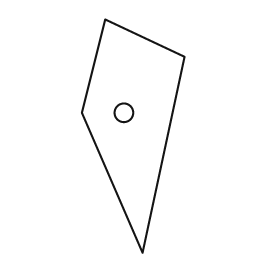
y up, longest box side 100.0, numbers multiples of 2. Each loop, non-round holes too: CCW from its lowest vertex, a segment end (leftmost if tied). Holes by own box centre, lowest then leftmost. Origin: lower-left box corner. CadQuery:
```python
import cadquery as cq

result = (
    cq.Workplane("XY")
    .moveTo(26.0, 0.0)
    .lineTo(44.0, 84.0)
    .lineTo(10.0, 100.0)
    .lineTo(0.0, 60.0)
    .close()
    .moveTo(18.0, 60.0)
    .circle(4.0)
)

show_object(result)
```